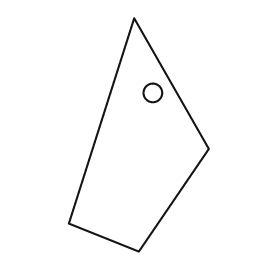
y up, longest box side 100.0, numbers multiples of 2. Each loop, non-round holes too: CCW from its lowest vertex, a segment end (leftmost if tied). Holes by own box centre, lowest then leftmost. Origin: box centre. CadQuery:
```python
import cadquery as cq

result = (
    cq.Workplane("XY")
    .moveTo(0.0, -50.0)
    .lineTo(30.0, -6.0)
    .lineTo(-2.0, 50.0)
    .lineTo(-30.0, -38.0)
    .close()
    .moveTo(6.0, 18.0)
    .circle(4.0)
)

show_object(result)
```